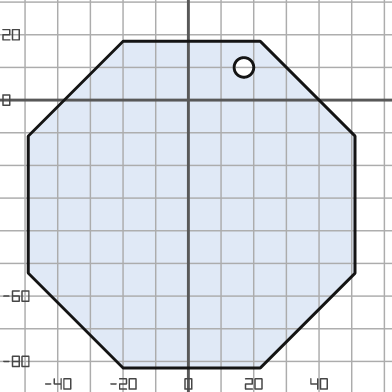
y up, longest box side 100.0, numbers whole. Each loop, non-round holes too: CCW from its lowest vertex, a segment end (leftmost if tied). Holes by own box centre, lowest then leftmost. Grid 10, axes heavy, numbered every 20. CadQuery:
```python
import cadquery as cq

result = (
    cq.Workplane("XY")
    .moveTo(-20.0, -82.0)
    .lineTo(22.0, -82.0)
    .lineTo(51.0, -53.0)
    .lineTo(51.0, -11.0)
    .lineTo(22.0, 18.0)
    .lineTo(-20.0, 18.0)
    .lineTo(-49.0, -11.0)
    .lineTo(-49.0, -53.0)
    .close()
    .moveTo(17.0, 10.0)
    .circle(3.0)
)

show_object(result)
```